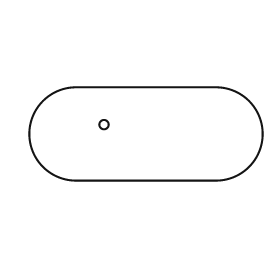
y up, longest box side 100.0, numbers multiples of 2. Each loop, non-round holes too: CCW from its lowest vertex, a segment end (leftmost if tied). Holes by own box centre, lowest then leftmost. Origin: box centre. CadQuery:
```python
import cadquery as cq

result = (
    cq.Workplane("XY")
    .moveTo(-30.0, -20.0)
    .lineTo(30.0, -20.0)
    .threePointArc((50.0, 0.0), (30.0, 20.0))
    .lineTo(-30.0, 20.0)
    .threePointArc((-50.0, 0.0), (-30.0, -20.0))
    .close()
    .moveTo(-18.0, 4.0)
    .circle(2.0)
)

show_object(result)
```